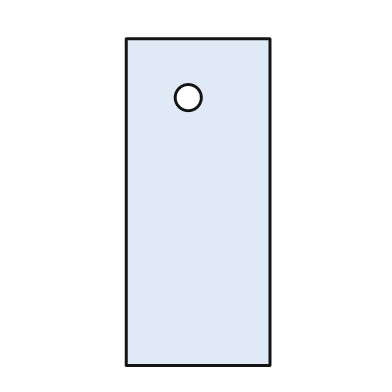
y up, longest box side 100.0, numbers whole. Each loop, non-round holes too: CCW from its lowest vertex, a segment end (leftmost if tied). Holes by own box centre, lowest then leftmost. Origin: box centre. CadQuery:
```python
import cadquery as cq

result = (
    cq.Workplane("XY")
    .moveTo(-22.0, -50.0)
    .lineTo(22.0, -50.0)
    .lineTo(22.0, 50.0)
    .lineTo(-22.0, 50.0)
    .close()
    .moveTo(-3.0, 32.0)
    .circle(4.0)
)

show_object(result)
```